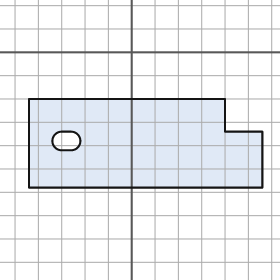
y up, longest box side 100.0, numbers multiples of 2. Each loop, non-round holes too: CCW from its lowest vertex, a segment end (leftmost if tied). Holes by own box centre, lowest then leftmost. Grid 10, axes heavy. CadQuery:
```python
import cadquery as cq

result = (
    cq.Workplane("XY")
    .moveTo(-44.0, -58.0)
    .lineTo(56.0, -58.0)
    .lineTo(56.0, -34.0)
    .lineTo(40.0, -34.0)
    .lineTo(40.0, -20.0)
    .lineTo(-44.0, -20.0)
    .close()
    .moveTo(-30.0, -42.0)
    .lineTo(-26.0, -42.0)
    .threePointArc((-22.0, -38.0), (-26.0, -34.0))
    .lineTo(-30.0, -34.0)
    .threePointArc((-34.0, -38.0), (-30.0, -42.0))
    .close()
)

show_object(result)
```